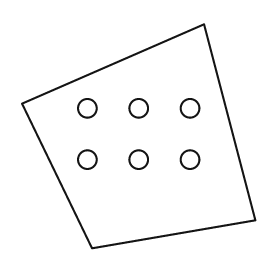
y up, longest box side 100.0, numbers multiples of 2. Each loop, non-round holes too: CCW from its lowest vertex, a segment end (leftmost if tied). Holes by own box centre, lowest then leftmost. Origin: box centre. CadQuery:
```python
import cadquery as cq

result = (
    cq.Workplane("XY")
    .moveTo(-20.0, -48.0)
    .lineTo(50.0, -36.0)
    .lineTo(28.0, 48.0)
    .lineTo(-50.0, 14.0)
    .close()
    .moveTo(-22.0, -10.0)
    .circle(4.0)
    .moveTo(0.0, -10.0)
    .circle(4.0)
    .moveTo(22.0, -10.0)
    .circle(4.0)
    .moveTo(-22.0, 12.0)
    .circle(4.0)
    .moveTo(0.0, 12.0)
    .circle(4.0)
    .moveTo(22.0, 12.0)
    .circle(4.0)
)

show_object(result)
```